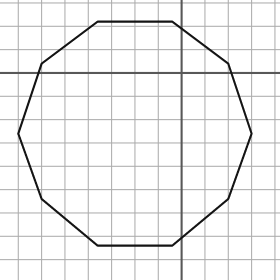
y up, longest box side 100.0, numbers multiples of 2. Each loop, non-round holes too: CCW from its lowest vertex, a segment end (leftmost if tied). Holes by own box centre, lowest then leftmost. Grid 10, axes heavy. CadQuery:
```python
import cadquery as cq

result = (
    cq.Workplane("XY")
    .moveTo(-36.0, -74.0)
    .lineTo(-4.0, -74.0)
    .lineTo(20.0, -54.0)
    .lineTo(30.0, -26.0)
    .lineTo(20.0, 4.0)
    .lineTo(-4.0, 22.0)
    .lineTo(-36.0, 22.0)
    .lineTo(-60.0, 4.0)
    .lineTo(-70.0, -26.0)
    .lineTo(-60.0, -54.0)
    .close()
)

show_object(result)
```